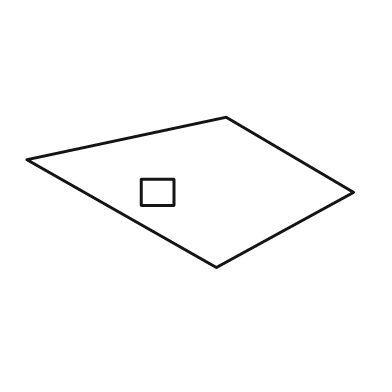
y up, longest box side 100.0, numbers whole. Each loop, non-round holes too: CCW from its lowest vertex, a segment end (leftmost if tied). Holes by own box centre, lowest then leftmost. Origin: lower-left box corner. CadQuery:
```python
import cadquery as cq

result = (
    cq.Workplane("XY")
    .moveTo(58.0, 0.0)
    .lineTo(100.0, 23.0)
    .lineTo(61.0, 46.0)
    .lineTo(0.0, 33.0)
    .close()
    .moveTo(35.0, 19.0)
    .lineTo(45.0, 19.0)
    .lineTo(45.0, 27.0)
    .lineTo(35.0, 27.0)
    .close()
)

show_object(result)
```